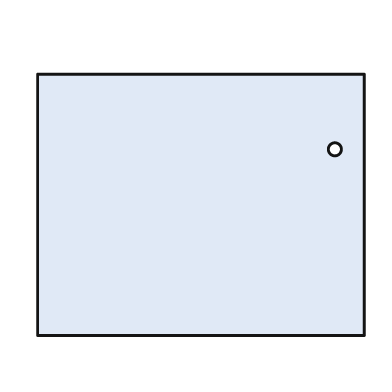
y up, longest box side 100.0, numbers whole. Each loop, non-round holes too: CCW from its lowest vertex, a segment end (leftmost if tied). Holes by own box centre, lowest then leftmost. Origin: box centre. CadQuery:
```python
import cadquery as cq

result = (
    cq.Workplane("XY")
    .moveTo(-50.0, -40.0)
    .lineTo(50.0, -40.0)
    .lineTo(50.0, 40.0)
    .lineTo(-50.0, 40.0)
    .close()
    .moveTo(41.0, 17.0)
    .circle(2.0)
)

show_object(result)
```